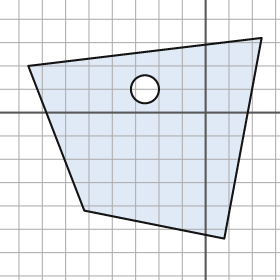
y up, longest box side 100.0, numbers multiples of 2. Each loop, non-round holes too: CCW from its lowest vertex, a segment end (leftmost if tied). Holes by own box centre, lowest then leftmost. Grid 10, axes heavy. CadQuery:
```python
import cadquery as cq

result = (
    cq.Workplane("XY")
    .moveTo(8.0, -54.0)
    .lineTo(24.0, 32.0)
    .lineTo(-76.0, 20.0)
    .lineTo(-52.0, -42.0)
    .close()
    .moveTo(-26.0, 10.0)
    .circle(6.0)
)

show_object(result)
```